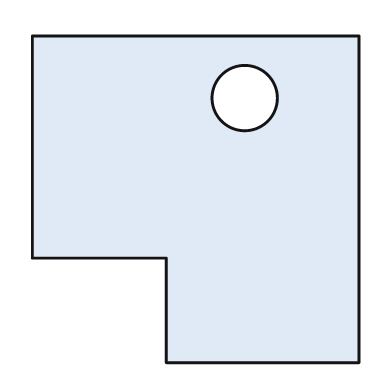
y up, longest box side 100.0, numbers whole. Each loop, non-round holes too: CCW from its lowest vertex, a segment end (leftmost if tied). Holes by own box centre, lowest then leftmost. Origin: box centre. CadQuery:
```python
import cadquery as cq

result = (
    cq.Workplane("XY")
    .moveTo(-9.0, -50.0)
    .lineTo(50.0, -50.0)
    .lineTo(50.0, 50.0)
    .lineTo(-50.0, 50.0)
    .lineTo(-50.0, -18.0)
    .lineTo(-9.0, -18.0)
    .close()
    .moveTo(15.0, 31.0)
    .circle(10.0)
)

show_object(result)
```